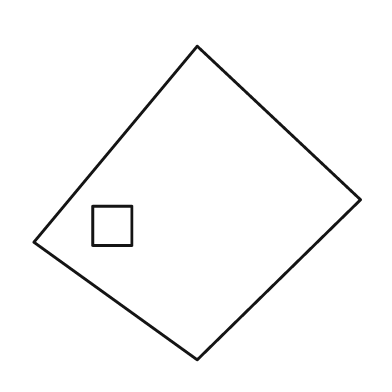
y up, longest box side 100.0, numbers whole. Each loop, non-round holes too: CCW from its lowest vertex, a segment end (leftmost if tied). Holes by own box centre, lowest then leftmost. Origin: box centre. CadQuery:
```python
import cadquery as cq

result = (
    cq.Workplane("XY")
    .moveTo(0.0, -48.0)
    .lineTo(50.0, 1.0)
    .lineTo(0.0, 48.0)
    .lineTo(-50.0, -12.0)
    .close()
    .moveTo(-32.0, -13.0)
    .lineTo(-20.0, -13.0)
    .lineTo(-20.0, -1.0)
    .lineTo(-32.0, -1.0)
    .close()
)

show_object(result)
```